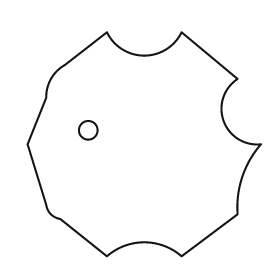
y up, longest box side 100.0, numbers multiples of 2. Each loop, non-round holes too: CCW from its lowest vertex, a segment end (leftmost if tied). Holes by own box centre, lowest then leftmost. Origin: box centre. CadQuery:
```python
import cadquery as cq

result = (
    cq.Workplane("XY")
    .moveTo(-16.0, -48.0)
    .threePointArc((0.0, -42.0), (16.0, -48.0))
    .lineTo(40.0, -30.0)
    .threePointArc((42.0, -14.0), (50.0, 0.0))
    .threePointArc((34.0, 10.0), (40.0, 28.0))
    .lineTo(16.0, 48.0)
    .threePointArc((0.0, 38.0), (-16.0, 48.0))
    .lineTo(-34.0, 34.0)
    .threePointArc((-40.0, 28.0), (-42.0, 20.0))
    .lineTo(-50.0, 0.0)
    .lineTo(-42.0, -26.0)
    .threePointArc((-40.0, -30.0), (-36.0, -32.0))
    .close()
    .moveTo(-24.0, 6.0)
    .circle(4.0)
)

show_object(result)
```